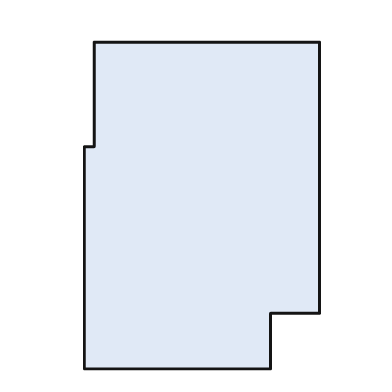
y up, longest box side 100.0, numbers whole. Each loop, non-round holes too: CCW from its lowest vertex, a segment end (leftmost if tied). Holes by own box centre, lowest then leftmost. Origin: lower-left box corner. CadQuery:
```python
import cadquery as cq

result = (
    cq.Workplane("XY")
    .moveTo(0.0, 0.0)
    .lineTo(57.0, 0.0)
    .lineTo(57.0, 17.0)
    .lineTo(72.0, 17.0)
    .lineTo(72.0, 100.0)
    .lineTo(3.0, 100.0)
    .lineTo(3.0, 68.0)
    .lineTo(0.0, 68.0)
    .close()
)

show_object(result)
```